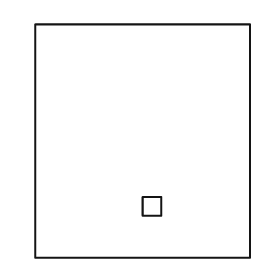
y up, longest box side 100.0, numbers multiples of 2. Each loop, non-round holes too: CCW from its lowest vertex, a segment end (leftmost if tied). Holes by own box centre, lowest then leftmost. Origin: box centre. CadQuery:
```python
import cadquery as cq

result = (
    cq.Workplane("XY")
    .moveTo(-46.0, -50.0)
    .lineTo(46.0, -50.0)
    .lineTo(46.0, 50.0)
    .lineTo(-46.0, 50.0)
    .close()
    .moveTo(0.0, -32.0)
    .lineTo(8.0, -32.0)
    .lineTo(8.0, -24.0)
    .lineTo(0.0, -24.0)
    .close()
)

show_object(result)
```